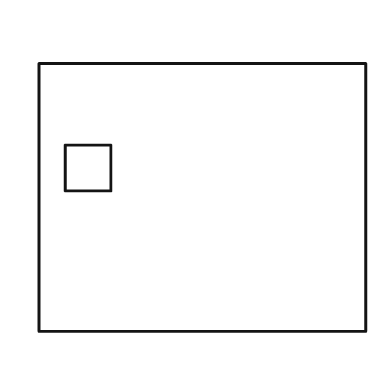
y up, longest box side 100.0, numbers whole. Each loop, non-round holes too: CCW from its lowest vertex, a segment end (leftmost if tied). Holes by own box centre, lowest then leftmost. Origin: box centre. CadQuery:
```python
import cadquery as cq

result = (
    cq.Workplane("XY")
    .moveTo(-50.0, -41.0)
    .lineTo(50.0, -41.0)
    .lineTo(50.0, 41.0)
    .lineTo(-50.0, 41.0)
    .close()
    .moveTo(-42.0, 2.0)
    .lineTo(-28.0, 2.0)
    .lineTo(-28.0, 16.0)
    .lineTo(-42.0, 16.0)
    .close()
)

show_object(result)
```